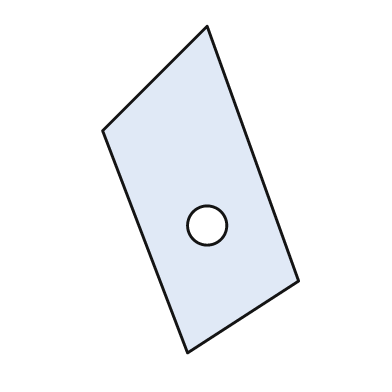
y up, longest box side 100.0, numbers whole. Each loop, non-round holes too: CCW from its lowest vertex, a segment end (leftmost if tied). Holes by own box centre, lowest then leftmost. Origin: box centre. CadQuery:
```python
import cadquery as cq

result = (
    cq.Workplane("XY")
    .moveTo(-4.0, -50.0)
    .lineTo(30.0, -28.0)
    .lineTo(2.0, 50.0)
    .lineTo(-30.0, 18.0)
    .close()
    .moveTo(2.0, -11.0)
    .circle(6.0)
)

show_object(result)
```